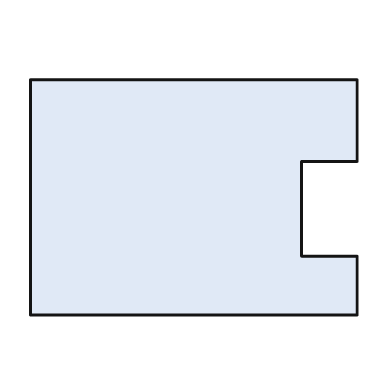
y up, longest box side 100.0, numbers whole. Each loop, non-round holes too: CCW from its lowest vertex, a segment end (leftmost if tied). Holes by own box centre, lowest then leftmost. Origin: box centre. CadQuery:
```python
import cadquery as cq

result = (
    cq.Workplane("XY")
    .moveTo(-50.0, -36.0)
    .lineTo(50.0, -36.0)
    .lineTo(50.0, -18.0)
    .lineTo(33.0, -18.0)
    .lineTo(33.0, 11.0)
    .lineTo(50.0, 11.0)
    .lineTo(50.0, 36.0)
    .lineTo(-50.0, 36.0)
    .close()
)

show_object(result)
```